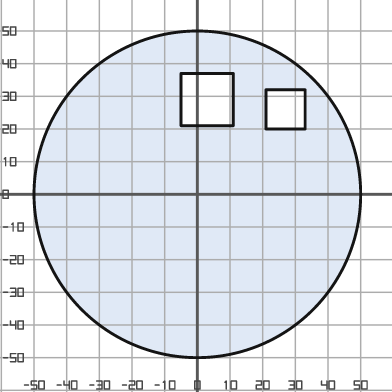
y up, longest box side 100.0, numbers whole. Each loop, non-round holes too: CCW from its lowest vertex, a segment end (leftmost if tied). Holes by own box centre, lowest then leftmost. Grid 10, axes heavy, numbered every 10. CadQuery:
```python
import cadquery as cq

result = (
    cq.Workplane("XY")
    .moveTo(0.0, 0.0)
    .circle(50.0)
    .moveTo(21.0, 20.0)
    .lineTo(33.0, 20.0)
    .lineTo(33.0, 32.0)
    .lineTo(21.0, 32.0)
    .close()
    .moveTo(-5.0, 21.0)
    .lineTo(11.0, 21.0)
    .lineTo(11.0, 37.0)
    .lineTo(-5.0, 37.0)
    .close()
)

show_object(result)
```